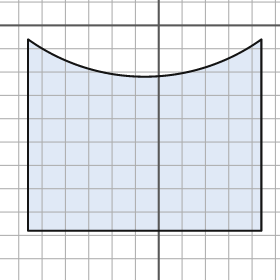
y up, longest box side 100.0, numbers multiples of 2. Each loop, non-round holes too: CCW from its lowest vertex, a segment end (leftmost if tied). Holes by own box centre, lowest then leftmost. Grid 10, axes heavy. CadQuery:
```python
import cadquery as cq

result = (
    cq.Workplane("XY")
    .moveTo(-56.0, -88.0)
    .lineTo(44.0, -88.0)
    .lineTo(44.0, -6.0)
    .threePointArc((-6.0, -22.0), (-56.0, -6.0))
    .close()
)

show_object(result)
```